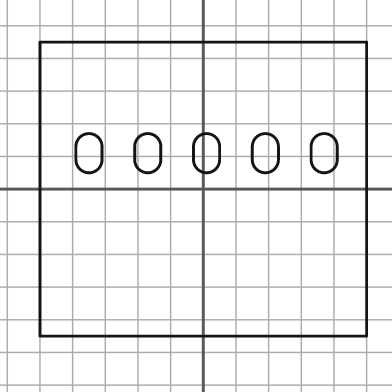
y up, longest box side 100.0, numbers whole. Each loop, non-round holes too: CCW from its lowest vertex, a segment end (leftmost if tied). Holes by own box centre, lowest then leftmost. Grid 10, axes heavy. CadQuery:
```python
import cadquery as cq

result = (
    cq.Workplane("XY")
    .moveTo(-50.0, -45.0)
    .lineTo(50.0, -45.0)
    .lineTo(50.0, 45.0)
    .lineTo(-50.0, 45.0)
    .close()
    .moveTo(-39.0, 9.0)
    .threePointArc((-35.0, 5.0), (-31.0, 9.0))
    .lineTo(-31.0, 13.0)
    .threePointArc((-35.0, 17.0), (-39.0, 13.0))
    .close()
    .moveTo(-21.0, 9.0)
    .threePointArc((-17.0, 5.0), (-13.0, 9.0))
    .lineTo(-13.0, 13.0)
    .threePointArc((-17.0, 17.0), (-21.0, 13.0))
    .close()
    .moveTo(-3.0, 9.0)
    .threePointArc((1.0, 5.0), (5.0, 9.0))
    .lineTo(5.0, 13.0)
    .threePointArc((1.0, 17.0), (-3.0, 13.0))
    .close()
    .moveTo(15.0, 9.0)
    .threePointArc((19.0, 5.0), (23.0, 9.0))
    .lineTo(23.0, 13.0)
    .threePointArc((19.0, 17.0), (15.0, 13.0))
    .close()
    .moveTo(33.0, 9.0)
    .threePointArc((37.0, 5.0), (41.0, 9.0))
    .lineTo(41.0, 13.0)
    .threePointArc((37.0, 17.0), (33.0, 13.0))
    .close()
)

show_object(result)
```